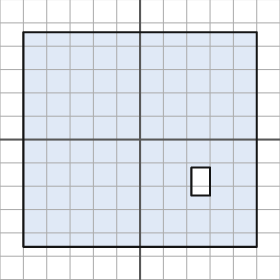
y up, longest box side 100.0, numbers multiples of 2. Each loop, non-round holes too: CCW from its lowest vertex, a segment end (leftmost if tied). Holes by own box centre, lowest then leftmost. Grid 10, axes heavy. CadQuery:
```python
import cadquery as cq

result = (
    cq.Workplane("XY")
    .moveTo(-50.0, -46.0)
    .lineTo(50.0, -46.0)
    .lineTo(50.0, 46.0)
    .lineTo(-50.0, 46.0)
    .close()
    .moveTo(22.0, -24.0)
    .lineTo(30.0, -24.0)
    .lineTo(30.0, -12.0)
    .lineTo(22.0, -12.0)
    .close()
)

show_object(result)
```